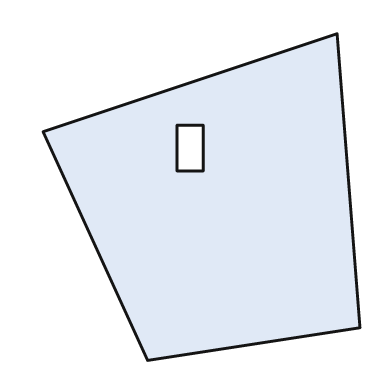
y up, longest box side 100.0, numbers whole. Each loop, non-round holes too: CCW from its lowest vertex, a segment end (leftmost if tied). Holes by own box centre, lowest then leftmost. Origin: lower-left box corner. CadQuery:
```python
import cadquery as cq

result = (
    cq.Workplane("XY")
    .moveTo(32.0, 0.0)
    .lineTo(97.0, 10.0)
    .lineTo(90.0, 100.0)
    .lineTo(0.0, 70.0)
    .close()
    .moveTo(41.0, 58.0)
    .lineTo(49.0, 58.0)
    .lineTo(49.0, 72.0)
    .lineTo(41.0, 72.0)
    .close()
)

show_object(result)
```